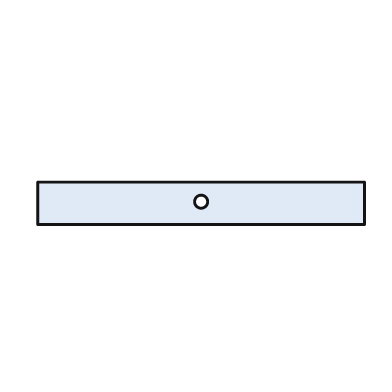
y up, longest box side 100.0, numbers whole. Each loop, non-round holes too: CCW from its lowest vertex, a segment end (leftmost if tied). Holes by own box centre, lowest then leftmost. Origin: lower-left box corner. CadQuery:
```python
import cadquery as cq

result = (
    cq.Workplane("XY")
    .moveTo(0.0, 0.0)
    .lineTo(100.0, 0.0)
    .lineTo(100.0, 13.0)
    .lineTo(0.0, 13.0)
    .close()
    .moveTo(50.0, 7.0)
    .circle(2.0)
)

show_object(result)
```